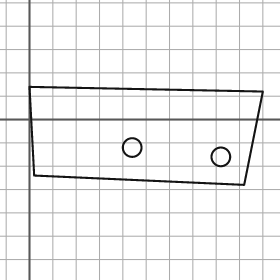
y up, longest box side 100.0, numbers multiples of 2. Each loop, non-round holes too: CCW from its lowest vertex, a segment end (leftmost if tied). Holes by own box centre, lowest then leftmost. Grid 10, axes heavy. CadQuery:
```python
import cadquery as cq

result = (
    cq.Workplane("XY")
    .moveTo(92.0, -28.0)
    .lineTo(100.0, 12.0)
    .lineTo(0.0, 14.0)
    .lineTo(2.0, -24.0)
    .close()
    .moveTo(82.0, -16.0)
    .circle(4.0)
    .moveTo(44.0, -12.0)
    .circle(4.0)
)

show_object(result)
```